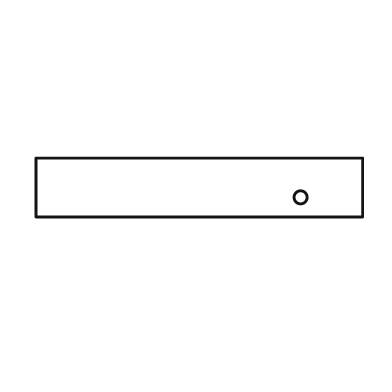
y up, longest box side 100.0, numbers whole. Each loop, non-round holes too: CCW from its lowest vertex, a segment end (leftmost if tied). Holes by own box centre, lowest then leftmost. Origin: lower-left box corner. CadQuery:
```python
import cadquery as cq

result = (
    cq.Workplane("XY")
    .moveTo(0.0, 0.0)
    .lineTo(100.0, 0.0)
    .lineTo(100.0, 18.0)
    .lineTo(0.0, 18.0)
    .close()
    .moveTo(81.0, 6.0)
    .circle(2.0)
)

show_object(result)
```